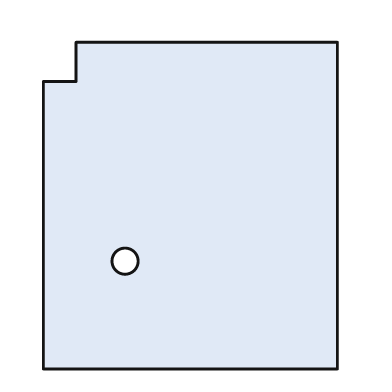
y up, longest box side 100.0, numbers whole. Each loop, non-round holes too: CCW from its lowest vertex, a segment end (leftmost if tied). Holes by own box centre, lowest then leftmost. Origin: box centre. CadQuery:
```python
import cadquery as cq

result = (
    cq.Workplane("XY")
    .moveTo(-45.0, -50.0)
    .lineTo(45.0, -50.0)
    .lineTo(45.0, 50.0)
    .lineTo(-35.0, 50.0)
    .lineTo(-35.0, 38.0)
    .lineTo(-45.0, 38.0)
    .close()
    .moveTo(-20.0, -17.0)
    .circle(4.0)
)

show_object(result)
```